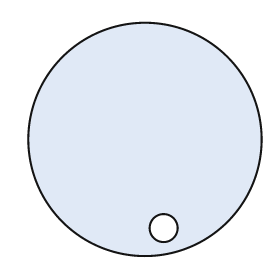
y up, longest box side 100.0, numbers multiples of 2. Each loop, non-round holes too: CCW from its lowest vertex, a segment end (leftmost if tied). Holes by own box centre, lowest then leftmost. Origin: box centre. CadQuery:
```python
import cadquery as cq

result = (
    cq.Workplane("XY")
    .moveTo(0.0, 0.0)
    .circle(50.0)
    .moveTo(8.0, -38.0)
    .circle(6.0)
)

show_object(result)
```